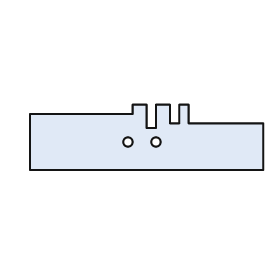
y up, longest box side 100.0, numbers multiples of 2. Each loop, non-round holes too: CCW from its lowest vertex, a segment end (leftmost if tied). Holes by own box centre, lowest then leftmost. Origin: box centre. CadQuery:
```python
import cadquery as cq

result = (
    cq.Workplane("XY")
    .moveTo(-50.0, -14.0)
    .lineTo(50.0, -14.0)
    .lineTo(50.0, 6.0)
    .lineTo(18.0, 6.0)
    .lineTo(18.0, 14.0)
    .lineTo(14.0, 14.0)
    .lineTo(14.0, 6.0)
    .lineTo(10.0, 6.0)
    .lineTo(10.0, 14.0)
    .lineTo(4.0, 14.0)
    .lineTo(4.0, 4.0)
    .lineTo(0.0, 4.0)
    .lineTo(0.0, 14.0)
    .lineTo(-6.0, 14.0)
    .lineTo(-6.0, 10.0)
    .lineTo(-50.0, 10.0)
    .close()
    .moveTo(-8.0, -2.0)
    .circle(2.0)
    .moveTo(4.0, -2.0)
    .circle(2.0)
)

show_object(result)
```